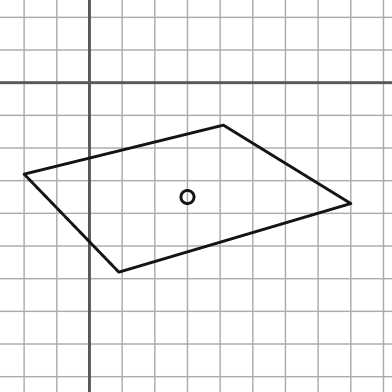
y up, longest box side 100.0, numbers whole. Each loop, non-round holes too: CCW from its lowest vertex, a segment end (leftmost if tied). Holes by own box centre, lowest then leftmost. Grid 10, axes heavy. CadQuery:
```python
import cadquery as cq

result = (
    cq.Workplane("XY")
    .moveTo(9.0, -58.0)
    .lineTo(80.0, -37.0)
    .lineTo(41.0, -13.0)
    .lineTo(-20.0, -28.0)
    .close()
    .moveTo(30.0, -35.0)
    .circle(2.0)
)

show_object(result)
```